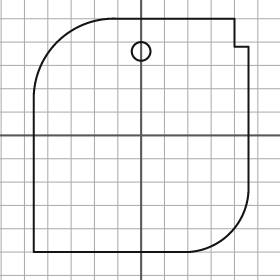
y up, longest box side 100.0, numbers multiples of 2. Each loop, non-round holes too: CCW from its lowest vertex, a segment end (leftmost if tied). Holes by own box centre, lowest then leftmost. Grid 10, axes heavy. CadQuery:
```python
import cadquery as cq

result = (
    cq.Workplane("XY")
    .moveTo(-46.0, -50.0)
    .lineTo(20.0, -50.0)
    .threePointArc((38.0, -42.0), (46.0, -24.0))
    .lineTo(46.0, 38.0)
    .lineTo(40.0, 38.0)
    .lineTo(40.0, 50.0)
    .lineTo(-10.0, 50.0)
    .threePointArc((-36.0, 40.0), (-46.0, 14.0))
    .close()
    .moveTo(0.0, 36.0)
    .circle(4.0)
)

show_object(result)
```